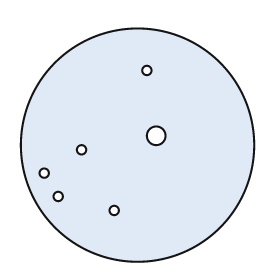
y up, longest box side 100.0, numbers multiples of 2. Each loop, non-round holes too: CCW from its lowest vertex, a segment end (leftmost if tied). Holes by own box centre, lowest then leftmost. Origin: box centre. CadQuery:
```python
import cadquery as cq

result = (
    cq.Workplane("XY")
    .moveTo(0.0, 0.0)
    .circle(50.0)
    .moveTo(-10.0, -28.0)
    .circle(2.0)
    .moveTo(-34.0, -22.0)
    .circle(2.0)
    .moveTo(-40.0, -12.0)
    .circle(2.0)
    .moveTo(-24.0, -2.0)
    .circle(2.0)
    .moveTo(8.0, 4.0)
    .circle(4.0)
    .moveTo(4.0, 32.0)
    .circle(2.0)
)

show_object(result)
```